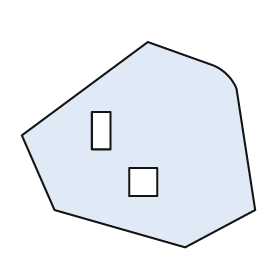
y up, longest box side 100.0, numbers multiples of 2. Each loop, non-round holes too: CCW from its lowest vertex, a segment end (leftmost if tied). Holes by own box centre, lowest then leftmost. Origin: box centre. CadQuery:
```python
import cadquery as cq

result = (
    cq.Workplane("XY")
    .moveTo(20.0, -44.0)
    .lineTo(50.0, -28.0)
    .lineTo(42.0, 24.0)
    .threePointArc((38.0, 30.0), (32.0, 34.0))
    .lineTo(4.0, 44.0)
    .lineTo(-50.0, 4.0)
    .lineTo(-36.0, -28.0)
    .close()
    .moveTo(-4.0, -22.0)
    .lineTo(8.0, -22.0)
    .lineTo(8.0, -10.0)
    .lineTo(-4.0, -10.0)
    .close()
    .moveTo(-20.0, -2.0)
    .lineTo(-12.0, -2.0)
    .lineTo(-12.0, 14.0)
    .lineTo(-20.0, 14.0)
    .close()
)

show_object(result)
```